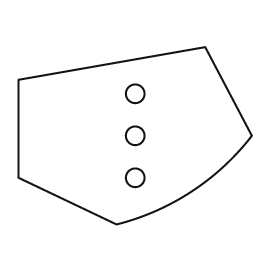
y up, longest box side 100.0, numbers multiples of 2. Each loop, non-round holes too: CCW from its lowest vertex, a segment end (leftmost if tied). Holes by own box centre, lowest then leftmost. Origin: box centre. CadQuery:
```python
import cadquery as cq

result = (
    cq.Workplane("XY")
    .moveTo(-8.0, -38.0)
    .threePointArc((24.0, -24.0), (50.0, 0.0))
    .lineTo(30.0, 38.0)
    .lineTo(-50.0, 24.0)
    .lineTo(-50.0, -18.0)
    .close()
    .moveTo(0.0, -18.0)
    .circle(4.0)
    .moveTo(0.0, 0.0)
    .circle(4.0)
    .moveTo(0.0, 18.0)
    .circle(4.0)
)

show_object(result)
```